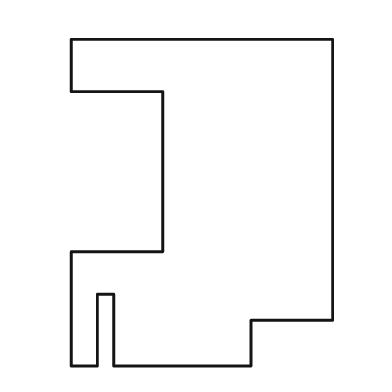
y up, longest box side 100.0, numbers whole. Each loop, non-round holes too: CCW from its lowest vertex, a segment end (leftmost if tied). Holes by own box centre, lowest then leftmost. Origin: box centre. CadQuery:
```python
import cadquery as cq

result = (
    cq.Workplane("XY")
    .moveTo(-40.0, -50.0)
    .lineTo(-32.0, -50.0)
    .lineTo(-32.0, -28.0)
    .lineTo(-27.0, -28.0)
    .lineTo(-27.0, -50.0)
    .lineTo(15.0, -50.0)
    .lineTo(15.0, -36.0)
    .lineTo(40.0, -36.0)
    .lineTo(40.0, 50.0)
    .lineTo(-40.0, 50.0)
    .lineTo(-40.0, 34.0)
    .lineTo(-12.0, 34.0)
    .lineTo(-12.0, -15.0)
    .lineTo(-40.0, -15.0)
    .close()
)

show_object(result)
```